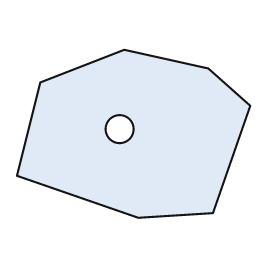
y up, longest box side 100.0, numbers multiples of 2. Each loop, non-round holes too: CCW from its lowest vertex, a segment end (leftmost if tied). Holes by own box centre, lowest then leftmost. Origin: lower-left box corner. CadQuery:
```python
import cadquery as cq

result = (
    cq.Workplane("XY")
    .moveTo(52.0, 0.0)
    .lineTo(84.0, 2.0)
    .lineTo(100.0, 48.0)
    .lineTo(82.0, 64.0)
    .lineTo(46.0, 72.0)
    .lineTo(10.0, 58.0)
    .lineTo(0.0, 18.0)
    .close()
    .moveTo(44.0, 38.0)
    .circle(6.0)
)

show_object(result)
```